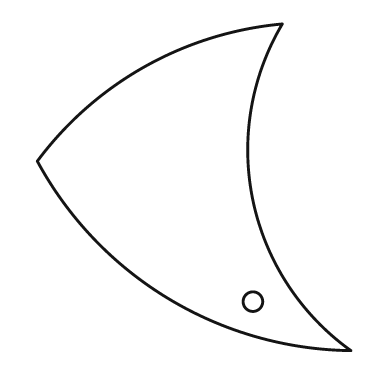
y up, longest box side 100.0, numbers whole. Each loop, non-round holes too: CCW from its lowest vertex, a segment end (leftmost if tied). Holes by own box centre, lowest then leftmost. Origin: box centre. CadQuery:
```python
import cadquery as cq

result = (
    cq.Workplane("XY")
    .moveTo(48.0, -50.0)
    .threePointArc((18.0, -4.0), (27.0, 50.0))
    .threePointArc((-15.0, 37.0), (-48.0, 8.0))
    .threePointArc((-8.0, -34.0), (48.0, -50.0))
    .close()
    .moveTo(18.0, -35.0)
    .circle(3.0)
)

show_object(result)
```